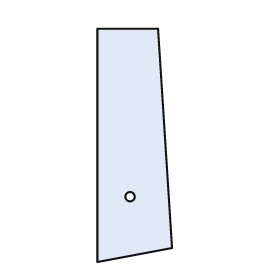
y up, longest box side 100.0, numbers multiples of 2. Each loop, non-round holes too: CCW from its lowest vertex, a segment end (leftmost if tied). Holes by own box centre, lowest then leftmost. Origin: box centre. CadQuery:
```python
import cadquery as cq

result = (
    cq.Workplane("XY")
    .moveTo(-16.0, -50.0)
    .lineTo(16.0, -44.0)
    .lineTo(10.0, 50.0)
    .lineTo(-16.0, 50.0)
    .close()
    .moveTo(-2.0, -22.0)
    .circle(2.0)
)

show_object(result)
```